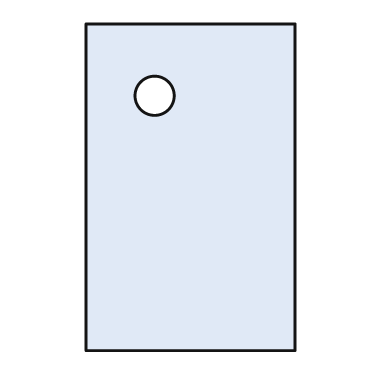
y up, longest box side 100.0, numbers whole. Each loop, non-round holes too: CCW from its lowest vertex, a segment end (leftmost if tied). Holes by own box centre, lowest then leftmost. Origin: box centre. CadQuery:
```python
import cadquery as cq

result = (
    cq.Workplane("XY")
    .moveTo(-32.0, -50.0)
    .lineTo(32.0, -50.0)
    .lineTo(32.0, 50.0)
    .lineTo(-32.0, 50.0)
    .close()
    .moveTo(-11.0, 28.0)
    .circle(6.0)
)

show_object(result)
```